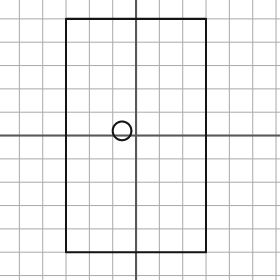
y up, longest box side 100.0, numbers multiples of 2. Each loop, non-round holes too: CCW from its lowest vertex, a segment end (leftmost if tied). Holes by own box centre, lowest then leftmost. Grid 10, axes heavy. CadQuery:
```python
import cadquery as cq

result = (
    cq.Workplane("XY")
    .moveTo(-30.0, -50.0)
    .lineTo(30.0, -50.0)
    .lineTo(30.0, 50.0)
    .lineTo(-30.0, 50.0)
    .close()
    .moveTo(-6.0, 2.0)
    .circle(4.0)
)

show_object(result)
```